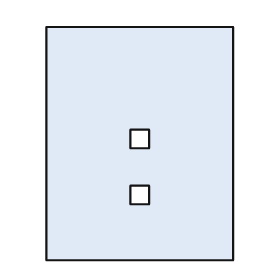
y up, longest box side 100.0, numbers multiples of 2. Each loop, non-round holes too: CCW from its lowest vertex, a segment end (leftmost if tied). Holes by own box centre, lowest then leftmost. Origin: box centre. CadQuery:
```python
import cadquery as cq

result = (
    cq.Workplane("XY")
    .moveTo(-40.0, -50.0)
    .lineTo(40.0, -50.0)
    .lineTo(40.0, 50.0)
    .lineTo(-40.0, 50.0)
    .close()
    .moveTo(-4.0, -26.0)
    .lineTo(4.0, -26.0)
    .lineTo(4.0, -18.0)
    .lineTo(-4.0, -18.0)
    .close()
    .moveTo(-4.0, -2.0)
    .lineTo(4.0, -2.0)
    .lineTo(4.0, 6.0)
    .lineTo(-4.0, 6.0)
    .close()
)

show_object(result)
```